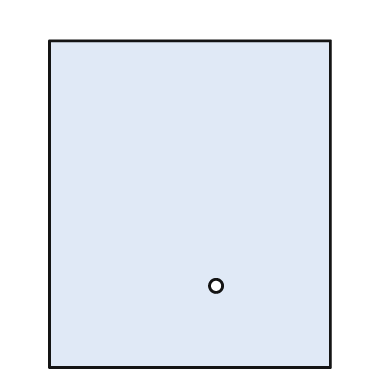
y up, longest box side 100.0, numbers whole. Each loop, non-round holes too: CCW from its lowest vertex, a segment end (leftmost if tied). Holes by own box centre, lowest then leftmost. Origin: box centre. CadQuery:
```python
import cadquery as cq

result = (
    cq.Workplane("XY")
    .moveTo(-43.0, -50.0)
    .lineTo(43.0, -50.0)
    .lineTo(43.0, 50.0)
    .lineTo(-43.0, 50.0)
    .close()
    .moveTo(8.0, -25.0)
    .circle(2.0)
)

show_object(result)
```